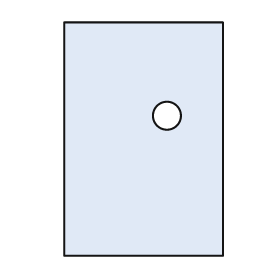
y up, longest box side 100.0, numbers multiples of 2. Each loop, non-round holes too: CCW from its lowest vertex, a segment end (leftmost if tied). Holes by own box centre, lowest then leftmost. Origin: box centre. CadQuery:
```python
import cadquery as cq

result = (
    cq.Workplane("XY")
    .moveTo(-34.0, -50.0)
    .lineTo(34.0, -50.0)
    .lineTo(34.0, 50.0)
    .lineTo(-34.0, 50.0)
    .close()
    .moveTo(10.0, 10.0)
    .circle(6.0)
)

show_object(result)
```